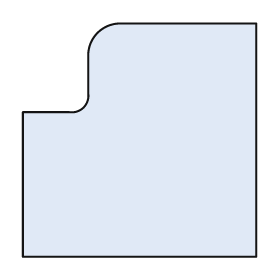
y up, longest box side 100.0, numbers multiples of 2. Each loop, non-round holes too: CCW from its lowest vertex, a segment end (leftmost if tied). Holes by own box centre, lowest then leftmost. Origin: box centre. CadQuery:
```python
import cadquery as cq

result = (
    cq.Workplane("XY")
    .moveTo(-50.0, -50.0)
    .lineTo(50.0, -50.0)
    .lineTo(50.0, 50.0)
    .lineTo(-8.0, 50.0)
    .threePointArc((-18.0, 46.0), (-22.0, 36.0))
    .lineTo(-22.0, 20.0)
    .threePointArc((-24.0, 14.0), (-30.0, 12.0))
    .lineTo(-50.0, 12.0)
    .close()
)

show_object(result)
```